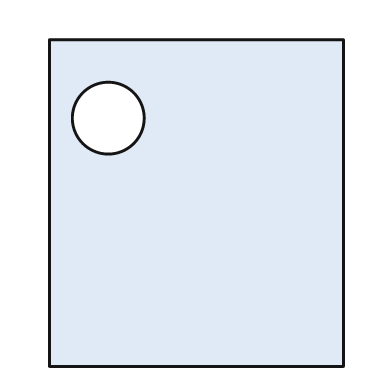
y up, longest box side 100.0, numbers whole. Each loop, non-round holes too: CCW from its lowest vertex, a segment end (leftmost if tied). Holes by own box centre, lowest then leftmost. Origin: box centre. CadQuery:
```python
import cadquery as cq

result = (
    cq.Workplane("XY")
    .moveTo(-45.0, -50.0)
    .lineTo(45.0, -50.0)
    .lineTo(45.0, 50.0)
    .lineTo(-45.0, 50.0)
    .close()
    .moveTo(-27.0, 26.0)
    .circle(11.0)
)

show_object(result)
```